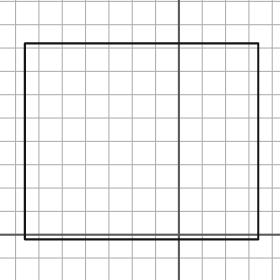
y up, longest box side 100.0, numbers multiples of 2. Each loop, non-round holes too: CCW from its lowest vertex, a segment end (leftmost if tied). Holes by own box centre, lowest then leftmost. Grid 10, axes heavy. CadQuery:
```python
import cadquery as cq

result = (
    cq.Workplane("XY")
    .moveTo(-66.0, -2.0)
    .lineTo(34.0, -2.0)
    .lineTo(34.0, 82.0)
    .lineTo(-66.0, 82.0)
    .close()
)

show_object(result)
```